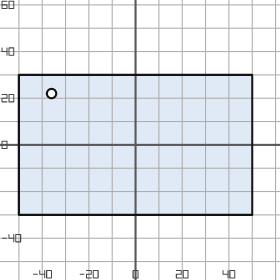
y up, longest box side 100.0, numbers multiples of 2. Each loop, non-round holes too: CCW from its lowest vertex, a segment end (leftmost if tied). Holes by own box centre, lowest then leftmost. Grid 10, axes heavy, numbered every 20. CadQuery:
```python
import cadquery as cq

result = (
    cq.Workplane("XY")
    .moveTo(-50.0, -30.0)
    .lineTo(50.0, -30.0)
    .lineTo(50.0, 30.0)
    .lineTo(-50.0, 30.0)
    .close()
    .moveTo(-36.0, 22.0)
    .circle(2.0)
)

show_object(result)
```